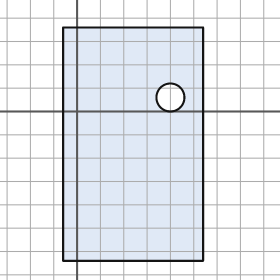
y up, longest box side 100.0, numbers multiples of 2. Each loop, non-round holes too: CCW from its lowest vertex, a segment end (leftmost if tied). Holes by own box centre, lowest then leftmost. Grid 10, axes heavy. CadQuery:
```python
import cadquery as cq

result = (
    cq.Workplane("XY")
    .moveTo(-6.0, -64.0)
    .lineTo(54.0, -64.0)
    .lineTo(54.0, 36.0)
    .lineTo(-6.0, 36.0)
    .close()
    .moveTo(40.0, 6.0)
    .circle(6.0)
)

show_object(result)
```